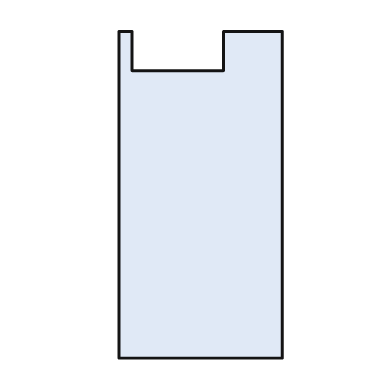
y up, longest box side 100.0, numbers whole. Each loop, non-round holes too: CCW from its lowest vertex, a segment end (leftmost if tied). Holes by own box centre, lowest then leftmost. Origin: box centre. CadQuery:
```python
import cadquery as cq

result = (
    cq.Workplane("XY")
    .moveTo(-25.0, -50.0)
    .lineTo(25.0, -50.0)
    .lineTo(25.0, 50.0)
    .lineTo(7.0, 50.0)
    .lineTo(7.0, 38.0)
    .lineTo(-21.0, 38.0)
    .lineTo(-21.0, 50.0)
    .lineTo(-25.0, 50.0)
    .close()
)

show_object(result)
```